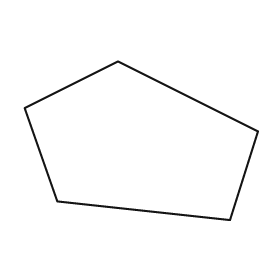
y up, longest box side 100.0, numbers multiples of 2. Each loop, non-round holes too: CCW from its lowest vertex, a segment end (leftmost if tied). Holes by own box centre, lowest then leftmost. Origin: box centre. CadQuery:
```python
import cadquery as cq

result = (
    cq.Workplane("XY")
    .moveTo(38.0, -34.0)
    .lineTo(50.0, 4.0)
    .lineTo(-10.0, 34.0)
    .lineTo(-50.0, 14.0)
    .lineTo(-36.0, -26.0)
    .close()
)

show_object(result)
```